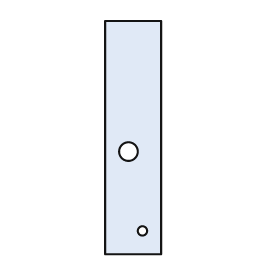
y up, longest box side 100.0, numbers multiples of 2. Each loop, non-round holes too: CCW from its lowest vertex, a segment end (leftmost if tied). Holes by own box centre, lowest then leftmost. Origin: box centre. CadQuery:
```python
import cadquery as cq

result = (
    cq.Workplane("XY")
    .moveTo(-12.0, -50.0)
    .lineTo(12.0, -50.0)
    .lineTo(12.0, 50.0)
    .lineTo(-12.0, 50.0)
    .close()
    .moveTo(4.0, -40.0)
    .circle(2.0)
    .moveTo(-2.0, -6.0)
    .circle(4.0)
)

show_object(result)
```